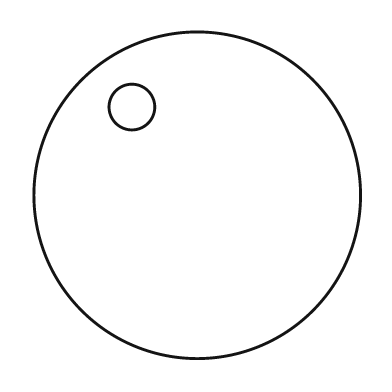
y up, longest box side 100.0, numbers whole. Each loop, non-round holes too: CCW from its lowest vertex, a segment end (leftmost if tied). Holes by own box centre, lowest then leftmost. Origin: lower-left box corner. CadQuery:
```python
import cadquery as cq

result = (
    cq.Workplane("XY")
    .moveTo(50.0, 50.0)
    .circle(50.0)
    .moveTo(30.0, 77.0)
    .circle(7.0)
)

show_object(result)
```